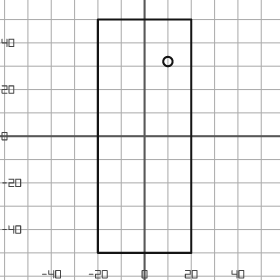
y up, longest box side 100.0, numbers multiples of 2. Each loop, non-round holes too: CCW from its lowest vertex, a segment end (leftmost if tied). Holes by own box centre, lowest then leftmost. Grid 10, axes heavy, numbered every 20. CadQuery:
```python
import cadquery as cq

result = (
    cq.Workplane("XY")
    .moveTo(-20.0, -50.0)
    .lineTo(20.0, -50.0)
    .lineTo(20.0, 50.0)
    .lineTo(-20.0, 50.0)
    .close()
    .moveTo(10.0, 32.0)
    .circle(2.0)
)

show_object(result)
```